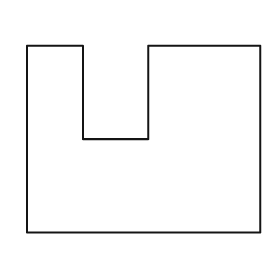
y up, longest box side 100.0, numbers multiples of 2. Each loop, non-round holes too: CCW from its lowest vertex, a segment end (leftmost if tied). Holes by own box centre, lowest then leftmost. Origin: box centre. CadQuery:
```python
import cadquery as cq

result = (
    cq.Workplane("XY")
    .moveTo(-50.0, -40.0)
    .lineTo(50.0, -40.0)
    .lineTo(50.0, 40.0)
    .lineTo(2.0, 40.0)
    .lineTo(2.0, 0.0)
    .lineTo(-26.0, 0.0)
    .lineTo(-26.0, 40.0)
    .lineTo(-50.0, 40.0)
    .close()
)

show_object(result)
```